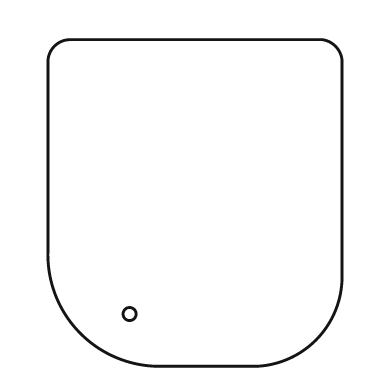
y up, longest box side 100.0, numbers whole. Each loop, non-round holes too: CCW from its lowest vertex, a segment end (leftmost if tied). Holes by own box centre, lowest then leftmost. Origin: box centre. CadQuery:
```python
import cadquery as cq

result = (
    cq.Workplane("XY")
    .moveTo(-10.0, -50.0)
    .lineTo(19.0, -50.0)
    .threePointArc((37.0, -42.0), (45.0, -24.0))
    .lineTo(45.0, 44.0)
    .threePointArc((43.0, 48.0), (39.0, 50.0))
    .lineTo(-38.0, 50.0)
    .threePointArc((-43.0, 48.0), (-45.0, 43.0))
    .lineTo(-45.0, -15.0)
    .threePointArc((-35.0, -40.0), (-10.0, -50.0))
    .close()
    .moveTo(-20.0, -34.0)
    .circle(2.0)
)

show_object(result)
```